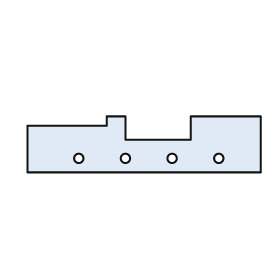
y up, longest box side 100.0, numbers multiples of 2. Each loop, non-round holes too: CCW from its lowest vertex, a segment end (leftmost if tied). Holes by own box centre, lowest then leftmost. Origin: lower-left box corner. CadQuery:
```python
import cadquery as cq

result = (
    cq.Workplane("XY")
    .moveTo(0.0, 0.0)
    .lineTo(100.0, 0.0)
    .lineTo(100.0, 24.0)
    .lineTo(70.0, 24.0)
    .lineTo(70.0, 14.0)
    .lineTo(42.0, 14.0)
    .lineTo(42.0, 24.0)
    .lineTo(34.0, 24.0)
    .lineTo(34.0, 20.0)
    .lineTo(0.0, 20.0)
    .close()
    .moveTo(22.0, 6.0)
    .circle(2.0)
    .moveTo(42.0, 6.0)
    .circle(2.0)
    .moveTo(62.0, 6.0)
    .circle(2.0)
    .moveTo(82.0, 6.0)
    .circle(2.0)
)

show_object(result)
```